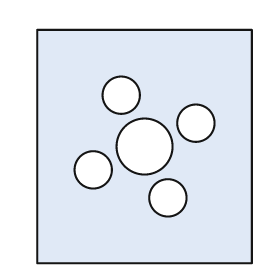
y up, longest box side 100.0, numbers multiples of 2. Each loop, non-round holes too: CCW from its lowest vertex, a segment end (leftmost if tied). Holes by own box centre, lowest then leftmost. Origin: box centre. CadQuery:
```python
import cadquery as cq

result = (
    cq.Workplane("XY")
    .moveTo(-46.0, -50.0)
    .lineTo(46.0, -50.0)
    .lineTo(46.0, 50.0)
    .lineTo(-46.0, 50.0)
    .close()
    .moveTo(10.0, -22.0)
    .circle(8.0)
    .moveTo(-22.0, -10.0)
    .circle(8.0)
    .moveTo(0.0, 0.0)
    .circle(12.0)
    .moveTo(22.0, 10.0)
    .circle(8.0)
    .moveTo(-10.0, 22.0)
    .circle(8.0)
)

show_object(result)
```